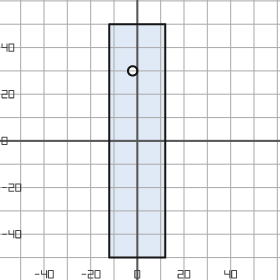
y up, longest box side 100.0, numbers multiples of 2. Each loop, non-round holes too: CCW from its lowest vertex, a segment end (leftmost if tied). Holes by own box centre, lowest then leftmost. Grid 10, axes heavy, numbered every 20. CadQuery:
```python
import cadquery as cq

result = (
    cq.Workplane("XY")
    .moveTo(-12.0, -50.0)
    .lineTo(12.0, -50.0)
    .lineTo(12.0, 50.0)
    .lineTo(-12.0, 50.0)
    .close()
    .moveTo(-2.0, 30.0)
    .circle(2.0)
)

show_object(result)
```